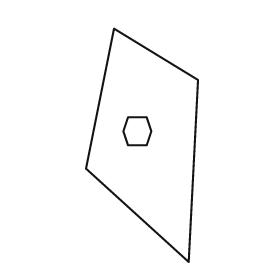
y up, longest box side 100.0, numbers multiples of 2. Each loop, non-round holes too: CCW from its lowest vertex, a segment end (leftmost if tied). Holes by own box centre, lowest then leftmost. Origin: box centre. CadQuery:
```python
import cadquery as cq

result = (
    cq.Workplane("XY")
    .moveTo(20.0, -50.0)
    .lineTo(24.0, 28.0)
    .lineTo(-12.0, 50.0)
    .lineTo(-24.0, -10.0)
    .close()
    .moveTo(-6.0, 0.0)
    .lineTo(2.0, 0.0)
    .lineTo(4.0, 6.0)
    .lineTo(2.0, 12.0)
    .lineTo(-6.0, 12.0)
    .lineTo(-8.0, 6.0)
    .close()
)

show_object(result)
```